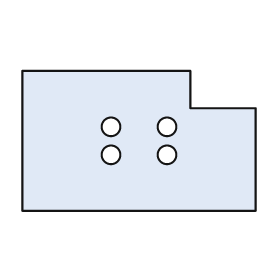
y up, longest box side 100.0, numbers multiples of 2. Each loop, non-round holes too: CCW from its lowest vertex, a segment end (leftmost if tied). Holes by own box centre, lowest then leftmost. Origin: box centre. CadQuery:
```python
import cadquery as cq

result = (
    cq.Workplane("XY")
    .moveTo(-50.0, -30.0)
    .lineTo(50.0, -30.0)
    .lineTo(50.0, 14.0)
    .lineTo(22.0, 14.0)
    .lineTo(22.0, 30.0)
    .lineTo(-50.0, 30.0)
    .close()
    .moveTo(-12.0, -6.0)
    .circle(4.0)
    .moveTo(12.0, -6.0)
    .circle(4.0)
    .moveTo(-12.0, 6.0)
    .circle(4.0)
    .moveTo(12.0, 6.0)
    .circle(4.0)
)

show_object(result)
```